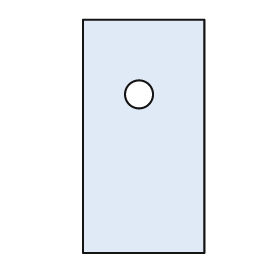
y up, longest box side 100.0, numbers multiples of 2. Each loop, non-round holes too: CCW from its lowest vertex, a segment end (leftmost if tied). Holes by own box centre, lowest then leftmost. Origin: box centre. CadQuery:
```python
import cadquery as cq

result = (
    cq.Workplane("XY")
    .moveTo(-26.0, -50.0)
    .lineTo(26.0, -50.0)
    .lineTo(26.0, 50.0)
    .lineTo(-26.0, 50.0)
    .close()
    .moveTo(-2.0, 18.0)
    .circle(6.0)
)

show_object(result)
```